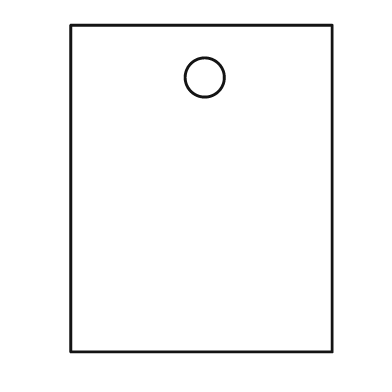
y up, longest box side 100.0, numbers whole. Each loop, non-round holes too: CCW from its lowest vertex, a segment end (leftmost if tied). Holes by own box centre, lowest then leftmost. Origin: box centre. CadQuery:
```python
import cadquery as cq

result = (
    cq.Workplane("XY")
    .moveTo(-40.0, -50.0)
    .lineTo(40.0, -50.0)
    .lineTo(40.0, 50.0)
    .lineTo(-40.0, 50.0)
    .close()
    .moveTo(1.0, 34.0)
    .circle(6.0)
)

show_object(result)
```